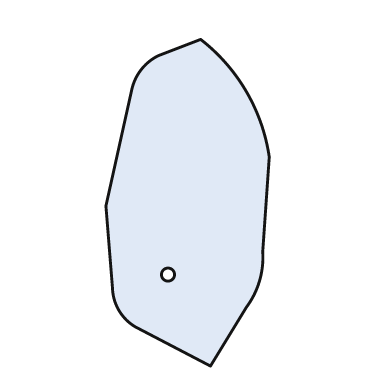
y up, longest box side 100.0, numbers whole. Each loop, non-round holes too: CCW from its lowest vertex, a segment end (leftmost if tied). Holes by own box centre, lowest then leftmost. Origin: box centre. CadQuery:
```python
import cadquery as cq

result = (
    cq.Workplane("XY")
    .moveTo(7.0, -50.0)
    .lineTo(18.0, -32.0)
    .threePointArc((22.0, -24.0), (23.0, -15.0))
    .lineTo(25.0, 14.0)
    .threePointArc((18.0, 34.0), (4.0, 50.0))
    .lineTo(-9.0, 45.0)
    .threePointArc((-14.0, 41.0), (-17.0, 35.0))
    .lineTo(-25.0, -1.0)
    .lineTo(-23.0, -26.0)
    .threePointArc((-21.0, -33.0), (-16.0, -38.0))
    .close()
    .moveTo(-6.0, -22.0)
    .circle(2.0)
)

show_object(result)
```